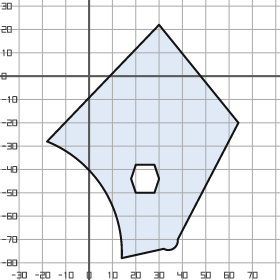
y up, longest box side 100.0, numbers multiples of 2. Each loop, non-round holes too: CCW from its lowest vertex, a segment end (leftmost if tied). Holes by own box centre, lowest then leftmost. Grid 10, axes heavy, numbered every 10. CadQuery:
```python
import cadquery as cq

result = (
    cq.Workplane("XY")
    .moveTo(14.0, -78.0)
    .lineTo(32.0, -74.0)
    .threePointArc((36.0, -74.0), (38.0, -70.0))
    .lineTo(64.0, -20.0)
    .lineTo(30.0, 22.0)
    .lineTo(-18.0, -28.0)
    .threePointArc((6.0, -48.0), (14.0, -78.0))
    .close()
    .moveTo(20.0, -50.0)
    .lineTo(28.0, -50.0)
    .lineTo(30.0, -44.0)
    .lineTo(28.0, -38.0)
    .lineTo(20.0, -38.0)
    .lineTo(18.0, -44.0)
    .close()
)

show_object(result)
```